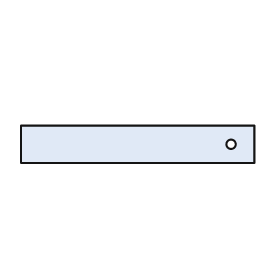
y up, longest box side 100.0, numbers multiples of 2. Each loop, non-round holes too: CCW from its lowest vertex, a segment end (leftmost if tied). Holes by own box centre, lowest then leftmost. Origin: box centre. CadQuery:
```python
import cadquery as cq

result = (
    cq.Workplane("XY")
    .moveTo(-50.0, -8.0)
    .lineTo(50.0, -8.0)
    .lineTo(50.0, 8.0)
    .lineTo(-50.0, 8.0)
    .close()
    .moveTo(40.0, 0.0)
    .circle(2.0)
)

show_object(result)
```